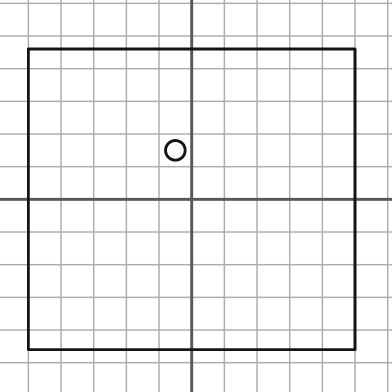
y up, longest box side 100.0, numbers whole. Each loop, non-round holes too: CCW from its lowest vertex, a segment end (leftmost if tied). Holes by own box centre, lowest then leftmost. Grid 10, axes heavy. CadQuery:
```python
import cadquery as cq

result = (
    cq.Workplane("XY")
    .moveTo(-50.0, -46.0)
    .lineTo(50.0, -46.0)
    .lineTo(50.0, 46.0)
    .lineTo(-50.0, 46.0)
    .close()
    .moveTo(-5.0, 15.0)
    .circle(3.0)
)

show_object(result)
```